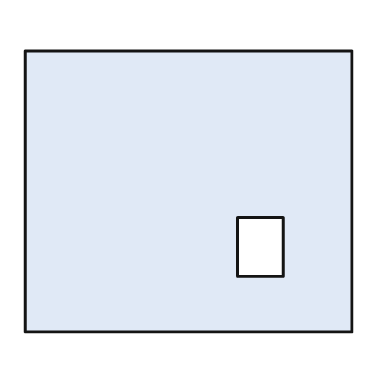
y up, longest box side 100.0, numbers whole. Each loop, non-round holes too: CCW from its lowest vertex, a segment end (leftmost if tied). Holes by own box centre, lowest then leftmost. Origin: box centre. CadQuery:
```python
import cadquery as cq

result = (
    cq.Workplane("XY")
    .moveTo(-50.0, -43.0)
    .lineTo(50.0, -43.0)
    .lineTo(50.0, 43.0)
    .lineTo(-50.0, 43.0)
    .close()
    .moveTo(15.0, -26.0)
    .lineTo(29.0, -26.0)
    .lineTo(29.0, -8.0)
    .lineTo(15.0, -8.0)
    .close()
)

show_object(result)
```